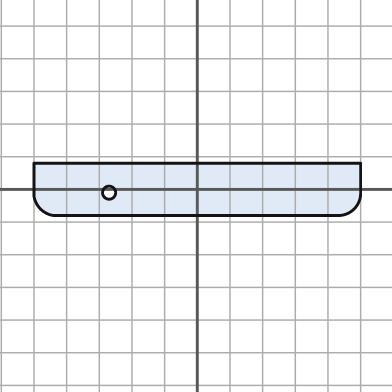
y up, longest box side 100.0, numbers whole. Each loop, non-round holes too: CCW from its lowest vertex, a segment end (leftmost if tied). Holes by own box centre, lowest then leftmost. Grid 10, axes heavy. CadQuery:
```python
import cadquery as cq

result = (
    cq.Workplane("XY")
    .moveTo(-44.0, -8.0)
    .lineTo(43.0, -8.0)
    .threePointArc((48.0, -6.0), (50.0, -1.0))
    .lineTo(50.0, 8.0)
    .lineTo(-50.0, 8.0)
    .lineTo(-50.0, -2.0)
    .threePointArc((-48.0, -6.0), (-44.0, -8.0))
    .close()
    .moveTo(-27.0, -1.0)
    .circle(2.0)
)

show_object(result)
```